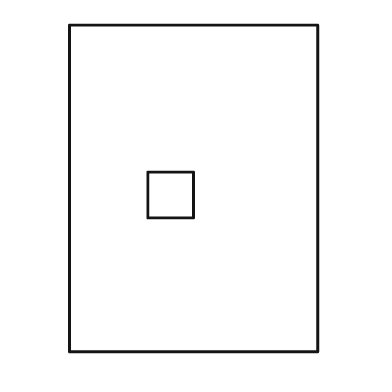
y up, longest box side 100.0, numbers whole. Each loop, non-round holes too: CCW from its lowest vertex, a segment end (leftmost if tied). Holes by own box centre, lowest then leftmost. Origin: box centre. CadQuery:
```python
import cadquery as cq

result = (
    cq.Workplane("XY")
    .moveTo(-38.0, -50.0)
    .lineTo(38.0, -50.0)
    .lineTo(38.0, 50.0)
    .lineTo(-38.0, 50.0)
    .close()
    .moveTo(-14.0, -9.0)
    .lineTo(0.0, -9.0)
    .lineTo(0.0, 5.0)
    .lineTo(-14.0, 5.0)
    .close()
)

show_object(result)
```